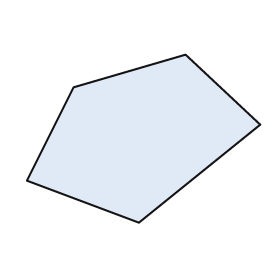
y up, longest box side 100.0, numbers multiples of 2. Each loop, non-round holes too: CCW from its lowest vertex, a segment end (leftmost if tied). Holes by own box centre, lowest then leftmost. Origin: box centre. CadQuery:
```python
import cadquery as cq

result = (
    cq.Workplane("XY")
    .moveTo(-2.0, -36.0)
    .lineTo(50.0, 6.0)
    .lineTo(18.0, 36.0)
    .lineTo(-30.0, 22.0)
    .lineTo(-50.0, -18.0)
    .close()
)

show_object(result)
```